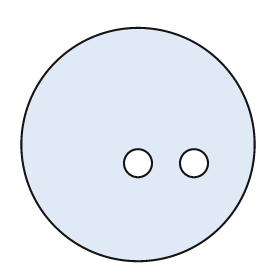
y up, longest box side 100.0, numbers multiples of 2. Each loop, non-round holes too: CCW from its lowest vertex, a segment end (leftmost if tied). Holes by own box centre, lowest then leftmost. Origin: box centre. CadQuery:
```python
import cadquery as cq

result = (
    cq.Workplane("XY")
    .moveTo(0.0, 0.0)
    .circle(50.0)
    .moveTo(0.0, -8.0)
    .circle(6.0)
    .moveTo(24.0, -8.0)
    .circle(6.0)
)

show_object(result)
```